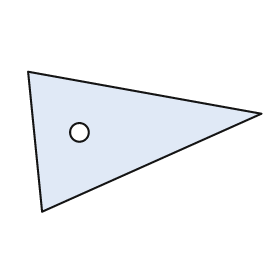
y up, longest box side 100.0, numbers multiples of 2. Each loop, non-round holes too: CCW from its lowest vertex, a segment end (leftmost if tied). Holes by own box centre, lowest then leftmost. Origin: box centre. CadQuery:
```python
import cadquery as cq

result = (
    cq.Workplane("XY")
    .moveTo(-44.0, -30.0)
    .lineTo(50.0, 12.0)
    .lineTo(-50.0, 30.0)
    .close()
    .moveTo(-28.0, 4.0)
    .circle(4.0)
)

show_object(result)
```